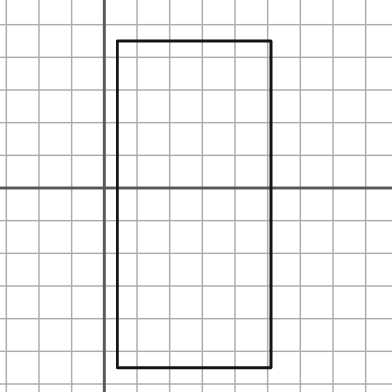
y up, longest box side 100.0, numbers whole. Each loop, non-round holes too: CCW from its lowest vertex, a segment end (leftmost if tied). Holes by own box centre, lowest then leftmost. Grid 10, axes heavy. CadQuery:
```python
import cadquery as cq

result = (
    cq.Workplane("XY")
    .moveTo(4.0, -55.0)
    .lineTo(51.0, -55.0)
    .lineTo(51.0, 45.0)
    .lineTo(4.0, 45.0)
    .close()
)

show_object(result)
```